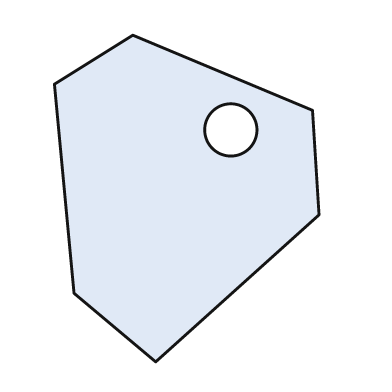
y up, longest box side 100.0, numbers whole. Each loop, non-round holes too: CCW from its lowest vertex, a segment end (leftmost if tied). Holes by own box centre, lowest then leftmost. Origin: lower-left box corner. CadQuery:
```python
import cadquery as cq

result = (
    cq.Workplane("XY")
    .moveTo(31.0, 0.0)
    .lineTo(81.0, 45.0)
    .lineTo(79.0, 77.0)
    .lineTo(24.0, 100.0)
    .lineTo(0.0, 85.0)
    .lineTo(6.0, 21.0)
    .close()
    .moveTo(54.0, 71.0)
    .circle(8.0)
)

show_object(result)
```